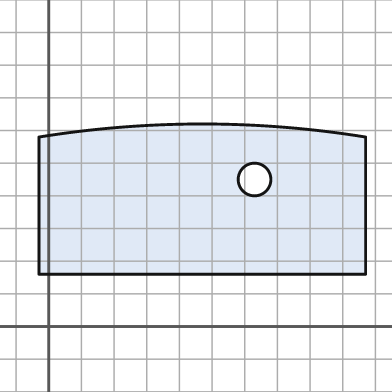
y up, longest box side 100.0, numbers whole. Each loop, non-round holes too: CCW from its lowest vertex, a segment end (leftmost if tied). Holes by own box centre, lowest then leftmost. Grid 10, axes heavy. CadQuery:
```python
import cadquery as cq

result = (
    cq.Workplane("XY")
    .moveTo(-3.0, 16.0)
    .lineTo(97.0, 16.0)
    .lineTo(97.0, 58.0)
    .threePointArc((47.0, 62.0), (-3.0, 58.0))
    .close()
    .moveTo(63.0, 45.0)
    .circle(5.0)
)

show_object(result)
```